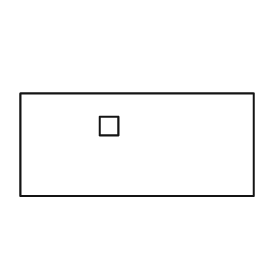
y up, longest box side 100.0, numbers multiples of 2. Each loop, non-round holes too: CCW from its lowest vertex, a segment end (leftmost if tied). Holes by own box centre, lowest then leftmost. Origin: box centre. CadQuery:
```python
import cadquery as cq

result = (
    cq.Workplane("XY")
    .moveTo(-50.0, -22.0)
    .lineTo(50.0, -22.0)
    .lineTo(50.0, 22.0)
    .lineTo(-50.0, 22.0)
    .close()
    .moveTo(-16.0, 4.0)
    .lineTo(-8.0, 4.0)
    .lineTo(-8.0, 12.0)
    .lineTo(-16.0, 12.0)
    .close()
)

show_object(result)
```